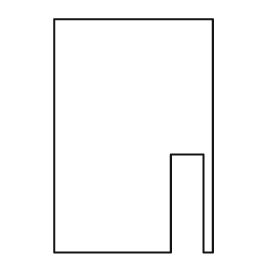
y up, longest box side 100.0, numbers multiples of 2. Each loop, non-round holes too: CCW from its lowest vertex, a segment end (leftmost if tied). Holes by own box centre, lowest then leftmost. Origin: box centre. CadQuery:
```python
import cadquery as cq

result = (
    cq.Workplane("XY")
    .moveTo(-34.0, -50.0)
    .lineTo(16.0, -50.0)
    .lineTo(16.0, -8.0)
    .lineTo(30.0, -8.0)
    .lineTo(30.0, -50.0)
    .lineTo(34.0, -50.0)
    .lineTo(34.0, 50.0)
    .lineTo(-34.0, 50.0)
    .close()
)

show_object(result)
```